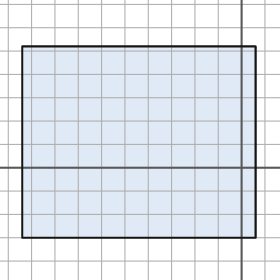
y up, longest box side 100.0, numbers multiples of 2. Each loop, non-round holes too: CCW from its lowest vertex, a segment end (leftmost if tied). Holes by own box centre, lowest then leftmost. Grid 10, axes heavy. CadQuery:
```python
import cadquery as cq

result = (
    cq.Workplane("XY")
    .moveTo(-94.0, -30.0)
    .lineTo(6.0, -30.0)
    .lineTo(6.0, 52.0)
    .lineTo(-94.0, 52.0)
    .close()
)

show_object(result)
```